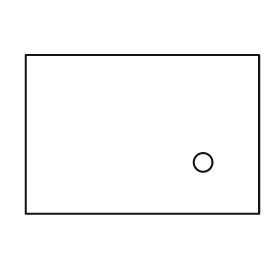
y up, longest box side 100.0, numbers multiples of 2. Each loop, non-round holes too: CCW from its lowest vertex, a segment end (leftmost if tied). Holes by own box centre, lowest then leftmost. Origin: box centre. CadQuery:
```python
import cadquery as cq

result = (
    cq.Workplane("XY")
    .moveTo(-50.0, -34.0)
    .lineTo(50.0, -34.0)
    .lineTo(50.0, 34.0)
    .lineTo(-50.0, 34.0)
    .close()
    .moveTo(26.0, -12.0)
    .circle(4.0)
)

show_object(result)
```